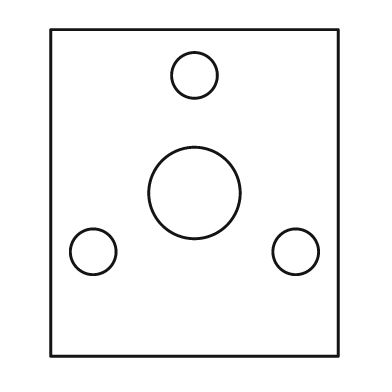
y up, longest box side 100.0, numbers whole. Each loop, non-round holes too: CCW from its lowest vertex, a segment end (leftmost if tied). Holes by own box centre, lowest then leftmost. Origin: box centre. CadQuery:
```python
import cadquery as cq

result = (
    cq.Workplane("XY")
    .moveTo(-44.0, -50.0)
    .lineTo(44.0, -50.0)
    .lineTo(44.0, 50.0)
    .lineTo(-44.0, 50.0)
    .close()
    .moveTo(-31.0, -18.0)
    .circle(7.0)
    .moveTo(31.0, -18.0)
    .circle(7.0)
    .moveTo(0.0, 0.0)
    .circle(14.0)
    .moveTo(0.0, 36.0)
    .circle(7.0)
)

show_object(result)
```